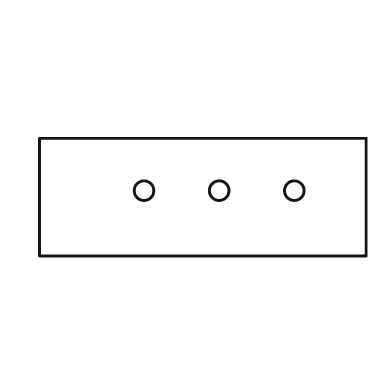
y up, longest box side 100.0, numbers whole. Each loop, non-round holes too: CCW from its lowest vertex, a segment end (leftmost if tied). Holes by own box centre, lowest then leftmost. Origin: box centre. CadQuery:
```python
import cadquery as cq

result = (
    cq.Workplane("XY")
    .moveTo(-50.0, -18.0)
    .lineTo(50.0, -18.0)
    .lineTo(50.0, 18.0)
    .lineTo(-50.0, 18.0)
    .close()
    .moveTo(-18.0, 2.0)
    .circle(3.0)
    .moveTo(5.0, 2.0)
    .circle(3.0)
    .moveTo(28.0, 2.0)
    .circle(3.0)
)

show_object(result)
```